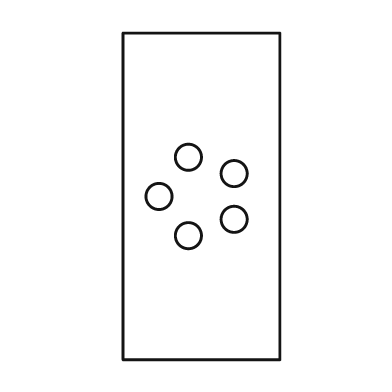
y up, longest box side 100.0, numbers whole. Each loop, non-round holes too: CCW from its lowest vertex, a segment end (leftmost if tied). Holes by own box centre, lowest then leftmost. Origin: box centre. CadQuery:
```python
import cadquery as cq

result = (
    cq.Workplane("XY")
    .moveTo(-24.0, -50.0)
    .lineTo(24.0, -50.0)
    .lineTo(24.0, 50.0)
    .lineTo(-24.0, 50.0)
    .close()
    .moveTo(-4.0, -12.0)
    .circle(4.0)
    .moveTo(10.0, -7.0)
    .circle(4.0)
    .moveTo(-13.0, 0.0)
    .circle(4.0)
    .moveTo(10.0, 7.0)
    .circle(4.0)
    .moveTo(-4.0, 12.0)
    .circle(4.0)
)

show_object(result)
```